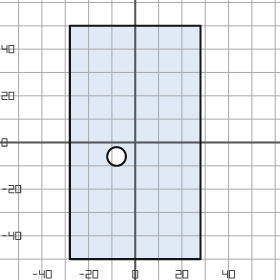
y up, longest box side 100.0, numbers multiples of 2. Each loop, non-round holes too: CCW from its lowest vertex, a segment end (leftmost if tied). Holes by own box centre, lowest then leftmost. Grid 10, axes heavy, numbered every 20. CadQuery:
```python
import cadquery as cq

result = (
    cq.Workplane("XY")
    .moveTo(-28.0, -50.0)
    .lineTo(28.0, -50.0)
    .lineTo(28.0, 50.0)
    .lineTo(-28.0, 50.0)
    .close()
    .moveTo(-8.0, -6.0)
    .circle(4.0)
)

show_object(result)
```